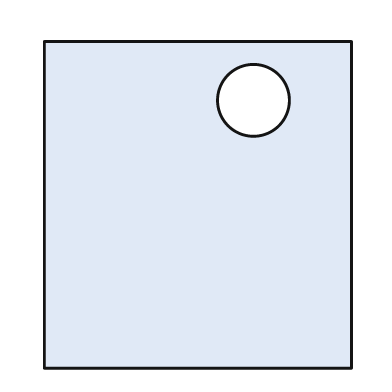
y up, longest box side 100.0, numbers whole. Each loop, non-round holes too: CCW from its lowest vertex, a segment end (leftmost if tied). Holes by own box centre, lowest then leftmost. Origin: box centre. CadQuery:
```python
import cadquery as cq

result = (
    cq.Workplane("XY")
    .moveTo(-47.0, -50.0)
    .lineTo(47.0, -50.0)
    .lineTo(47.0, 50.0)
    .lineTo(-47.0, 50.0)
    .close()
    .moveTo(17.0, 32.0)
    .circle(11.0)
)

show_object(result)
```